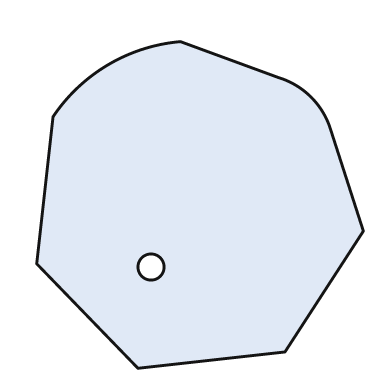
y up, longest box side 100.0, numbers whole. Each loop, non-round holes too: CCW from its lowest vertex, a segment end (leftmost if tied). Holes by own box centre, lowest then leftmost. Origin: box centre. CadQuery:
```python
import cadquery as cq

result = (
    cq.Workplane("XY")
    .moveTo(-19.0, -50.0)
    .lineTo(26.0, -45.0)
    .lineTo(50.0, -8.0)
    .lineTo(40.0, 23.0)
    .threePointArc((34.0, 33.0), (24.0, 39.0))
    .lineTo(-6.0, 50.0)
    .threePointArc((-28.0, 43.0), (-45.0, 27.0))
    .lineTo(-50.0, -18.0)
    .close()
    .moveTo(-15.0, -19.0)
    .circle(4.0)
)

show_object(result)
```